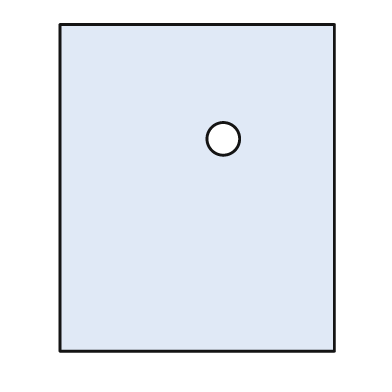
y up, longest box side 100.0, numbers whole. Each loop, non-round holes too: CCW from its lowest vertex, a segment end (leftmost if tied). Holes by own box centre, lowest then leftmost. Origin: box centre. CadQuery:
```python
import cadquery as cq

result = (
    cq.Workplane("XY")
    .moveTo(-42.0, -50.0)
    .lineTo(42.0, -50.0)
    .lineTo(42.0, 50.0)
    .lineTo(-42.0, 50.0)
    .close()
    .moveTo(8.0, 15.0)
    .circle(5.0)
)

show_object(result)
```